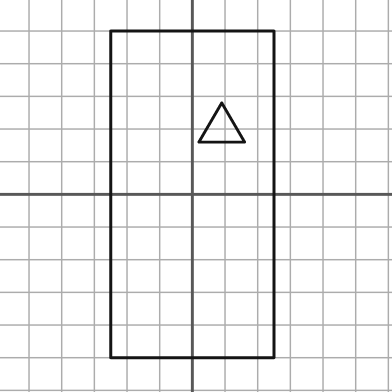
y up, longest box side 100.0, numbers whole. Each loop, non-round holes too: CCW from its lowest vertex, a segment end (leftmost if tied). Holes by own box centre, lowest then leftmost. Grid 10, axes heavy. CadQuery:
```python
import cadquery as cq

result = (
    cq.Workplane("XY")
    .moveTo(-25.0, -50.0)
    .lineTo(25.0, -50.0)
    .lineTo(25.0, 50.0)
    .lineTo(-25.0, 50.0)
    .close()
    .moveTo(2.0, 16.0)
    .lineTo(16.0, 16.0)
    .lineTo(9.0, 28.0)
    .close()
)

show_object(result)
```